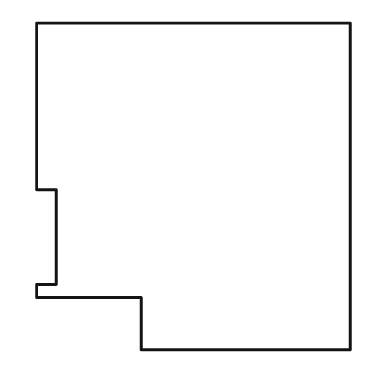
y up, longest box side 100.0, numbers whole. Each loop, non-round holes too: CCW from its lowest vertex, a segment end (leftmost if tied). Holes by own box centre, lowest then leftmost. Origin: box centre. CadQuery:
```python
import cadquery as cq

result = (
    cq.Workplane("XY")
    .moveTo(-16.0, -50.0)
    .lineTo(48.0, -50.0)
    .lineTo(48.0, 50.0)
    .lineTo(-48.0, 50.0)
    .lineTo(-48.0, -1.0)
    .lineTo(-42.0, -1.0)
    .lineTo(-42.0, -30.0)
    .lineTo(-48.0, -30.0)
    .lineTo(-48.0, -34.0)
    .lineTo(-16.0, -34.0)
    .close()
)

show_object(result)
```